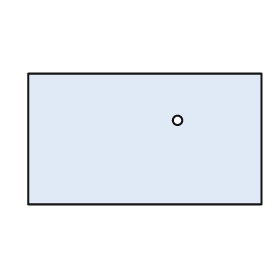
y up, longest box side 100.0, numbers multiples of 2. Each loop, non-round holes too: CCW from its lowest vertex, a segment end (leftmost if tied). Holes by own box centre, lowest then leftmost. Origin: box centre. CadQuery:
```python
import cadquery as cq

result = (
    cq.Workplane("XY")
    .moveTo(-50.0, -28.0)
    .lineTo(50.0, -28.0)
    .lineTo(50.0, 28.0)
    .lineTo(-50.0, 28.0)
    .close()
    .moveTo(14.0, 8.0)
    .circle(2.0)
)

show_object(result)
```